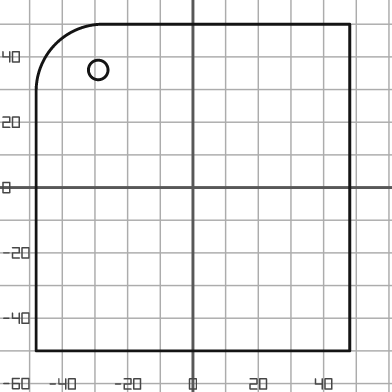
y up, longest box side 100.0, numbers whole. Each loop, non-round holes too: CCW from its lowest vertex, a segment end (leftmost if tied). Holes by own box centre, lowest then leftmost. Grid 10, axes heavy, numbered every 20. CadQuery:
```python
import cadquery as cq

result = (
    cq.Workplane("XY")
    .moveTo(-48.0, -50.0)
    .lineTo(48.0, -50.0)
    .lineTo(48.0, 50.0)
    .lineTo(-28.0, 50.0)
    .threePointArc((-42.0, 44.0), (-48.0, 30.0))
    .close()
    .moveTo(-29.0, 36.0)
    .circle(3.0)
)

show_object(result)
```